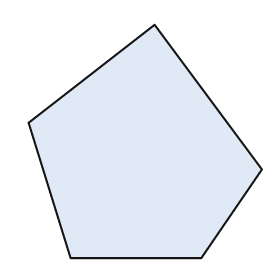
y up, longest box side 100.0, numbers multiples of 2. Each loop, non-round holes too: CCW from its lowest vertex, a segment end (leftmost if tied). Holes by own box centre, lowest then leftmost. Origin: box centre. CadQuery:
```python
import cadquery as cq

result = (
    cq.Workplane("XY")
    .moveTo(-32.0, -50.0)
    .lineTo(24.0, -50.0)
    .lineTo(50.0, -12.0)
    .lineTo(4.0, 50.0)
    .lineTo(-50.0, 8.0)
    .close()
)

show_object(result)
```